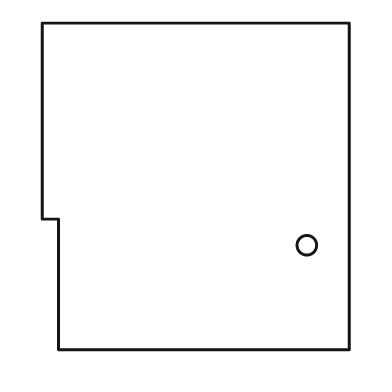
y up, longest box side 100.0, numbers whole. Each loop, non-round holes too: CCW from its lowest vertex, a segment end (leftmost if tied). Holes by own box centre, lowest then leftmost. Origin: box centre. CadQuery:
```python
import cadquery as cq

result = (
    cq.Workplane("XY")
    .moveTo(-42.0, -50.0)
    .lineTo(47.0, -50.0)
    .lineTo(47.0, 50.0)
    .lineTo(-47.0, 50.0)
    .lineTo(-47.0, -10.0)
    .lineTo(-42.0, -10.0)
    .close()
    .moveTo(34.0, -18.0)
    .circle(3.0)
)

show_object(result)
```